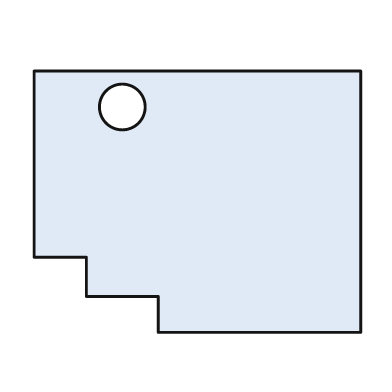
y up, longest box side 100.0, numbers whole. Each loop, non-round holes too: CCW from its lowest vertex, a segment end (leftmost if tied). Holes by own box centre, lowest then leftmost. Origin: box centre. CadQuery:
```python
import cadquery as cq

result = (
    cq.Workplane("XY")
    .moveTo(-12.0, -40.0)
    .lineTo(50.0, -40.0)
    .lineTo(50.0, 40.0)
    .lineTo(-50.0, 40.0)
    .lineTo(-50.0, -17.0)
    .lineTo(-34.0, -17.0)
    .lineTo(-34.0, -29.0)
    .lineTo(-12.0, -29.0)
    .close()
    .moveTo(-23.0, 29.0)
    .circle(7.0)
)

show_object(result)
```